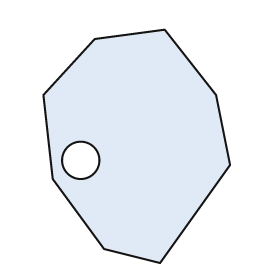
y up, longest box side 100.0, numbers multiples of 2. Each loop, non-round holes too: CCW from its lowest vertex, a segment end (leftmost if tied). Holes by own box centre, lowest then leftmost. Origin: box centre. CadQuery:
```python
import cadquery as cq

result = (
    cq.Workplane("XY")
    .moveTo(10.0, -50.0)
    .lineTo(40.0, -8.0)
    .lineTo(34.0, 22.0)
    .lineTo(12.0, 50.0)
    .lineTo(-18.0, 46.0)
    .lineTo(-40.0, 22.0)
    .lineTo(-36.0, -14.0)
    .lineTo(-14.0, -44.0)
    .close()
    .moveTo(-24.0, -6.0)
    .circle(8.0)
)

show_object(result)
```